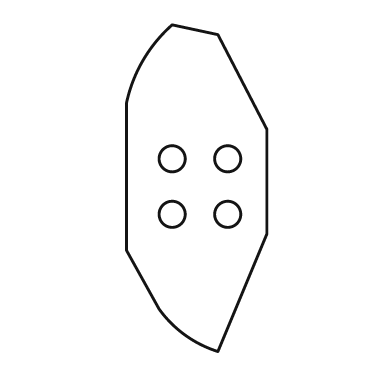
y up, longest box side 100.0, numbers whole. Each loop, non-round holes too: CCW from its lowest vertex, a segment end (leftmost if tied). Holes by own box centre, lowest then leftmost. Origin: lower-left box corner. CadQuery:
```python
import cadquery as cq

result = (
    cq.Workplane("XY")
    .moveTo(28.0, 0.0)
    .lineTo(43.0, 36.0)
    .lineTo(43.0, 68.0)
    .lineTo(28.0, 97.0)
    .lineTo(14.0, 100.0)
    .threePointArc((5.0, 89.0), (0.0, 76.0))
    .lineTo(0.0, 31.0)
    .lineTo(10.0, 13.0)
    .threePointArc((18.0, 5.0), (28.0, 0.0))
    .close()
    .moveTo(14.0, 42.0)
    .circle(4.0)
    .moveTo(31.0, 42.0)
    .circle(4.0)
    .moveTo(14.0, 59.0)
    .circle(4.0)
    .moveTo(31.0, 59.0)
    .circle(4.0)
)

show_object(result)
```